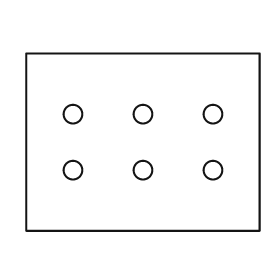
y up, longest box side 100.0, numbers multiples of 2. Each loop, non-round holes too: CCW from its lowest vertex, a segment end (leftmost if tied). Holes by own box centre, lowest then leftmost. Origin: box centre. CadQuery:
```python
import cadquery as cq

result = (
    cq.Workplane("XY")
    .moveTo(-50.0, -38.0)
    .lineTo(50.0, -38.0)
    .lineTo(50.0, 38.0)
    .lineTo(-50.0, 38.0)
    .close()
    .moveTo(-30.0, -12.0)
    .circle(4.0)
    .moveTo(0.0, -12.0)
    .circle(4.0)
    .moveTo(30.0, -12.0)
    .circle(4.0)
    .moveTo(-30.0, 12.0)
    .circle(4.0)
    .moveTo(0.0, 12.0)
    .circle(4.0)
    .moveTo(30.0, 12.0)
    .circle(4.0)
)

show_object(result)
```